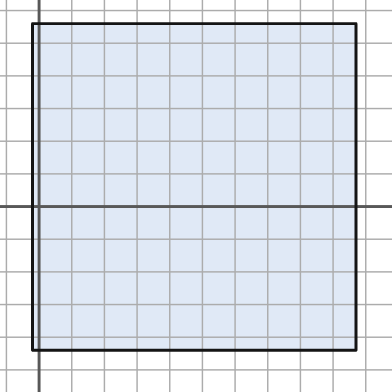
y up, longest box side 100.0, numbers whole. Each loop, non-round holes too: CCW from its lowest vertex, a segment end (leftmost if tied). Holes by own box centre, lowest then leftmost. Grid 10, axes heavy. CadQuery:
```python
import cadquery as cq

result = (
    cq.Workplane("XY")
    .moveTo(-2.0, -44.0)
    .lineTo(97.0, -44.0)
    .lineTo(97.0, 56.0)
    .lineTo(-2.0, 56.0)
    .close()
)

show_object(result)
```